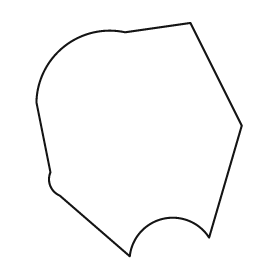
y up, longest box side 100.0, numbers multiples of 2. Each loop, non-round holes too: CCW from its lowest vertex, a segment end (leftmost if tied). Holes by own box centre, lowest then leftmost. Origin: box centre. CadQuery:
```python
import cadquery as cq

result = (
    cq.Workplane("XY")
    .moveTo(-4.0, -50.0)
    .threePointArc((10.0, -34.0), (30.0, -42.0))
    .lineTo(44.0, 6.0)
    .lineTo(22.0, 50.0)
    .lineTo(-6.0, 46.0)
    .threePointArc((-32.0, 40.0), (-44.0, 16.0))
    .lineTo(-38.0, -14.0)
    .threePointArc((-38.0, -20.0), (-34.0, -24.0))
    .close()
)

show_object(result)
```